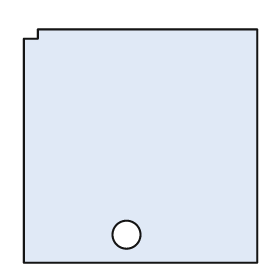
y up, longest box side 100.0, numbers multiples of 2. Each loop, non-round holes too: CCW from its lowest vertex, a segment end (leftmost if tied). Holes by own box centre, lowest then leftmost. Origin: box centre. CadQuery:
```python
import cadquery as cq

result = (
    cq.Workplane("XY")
    .moveTo(-50.0, -50.0)
    .lineTo(50.0, -50.0)
    .lineTo(50.0, 50.0)
    .lineTo(-44.0, 50.0)
    .lineTo(-44.0, 46.0)
    .lineTo(-50.0, 46.0)
    .close()
    .moveTo(-6.0, -38.0)
    .circle(6.0)
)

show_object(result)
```